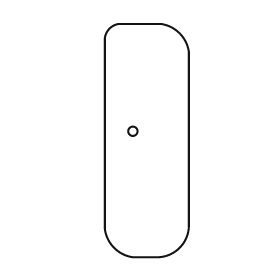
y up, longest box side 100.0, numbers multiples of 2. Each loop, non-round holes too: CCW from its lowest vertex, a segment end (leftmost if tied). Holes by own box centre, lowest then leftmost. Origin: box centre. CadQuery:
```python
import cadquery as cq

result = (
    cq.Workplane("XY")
    .moveTo(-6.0, -50.0)
    .lineTo(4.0, -50.0)
    .threePointArc((14.0, -46.0), (18.0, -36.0))
    .lineTo(18.0, 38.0)
    .threePointArc((14.0, 46.0), (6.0, 50.0))
    .lineTo(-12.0, 50.0)
    .threePointArc((-16.0, 48.0), (-18.0, 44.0))
    .lineTo(-18.0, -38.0)
    .threePointArc((-14.0, -46.0), (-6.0, -50.0))
    .close()
    .moveTo(-6.0, 4.0)
    .circle(2.0)
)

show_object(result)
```